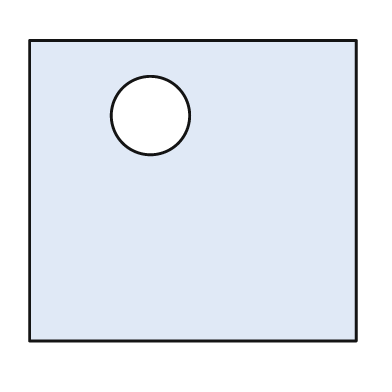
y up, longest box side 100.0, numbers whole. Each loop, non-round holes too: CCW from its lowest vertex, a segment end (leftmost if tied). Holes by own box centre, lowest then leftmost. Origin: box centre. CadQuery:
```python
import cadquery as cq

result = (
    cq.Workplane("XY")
    .moveTo(-50.0, -46.0)
    .lineTo(50.0, -46.0)
    .lineTo(50.0, 46.0)
    .lineTo(-50.0, 46.0)
    .close()
    .moveTo(-13.0, 23.0)
    .circle(12.0)
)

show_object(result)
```